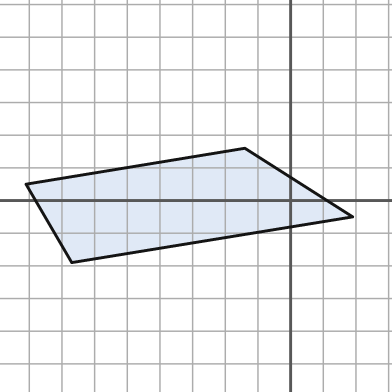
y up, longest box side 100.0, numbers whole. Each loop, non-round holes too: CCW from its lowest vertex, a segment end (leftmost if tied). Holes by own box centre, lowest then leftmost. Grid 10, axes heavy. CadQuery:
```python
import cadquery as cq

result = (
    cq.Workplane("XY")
    .moveTo(-67.0, -19.0)
    .lineTo(19.0, -5.0)
    .lineTo(-14.0, 16.0)
    .lineTo(-81.0, 5.0)
    .close()
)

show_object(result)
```